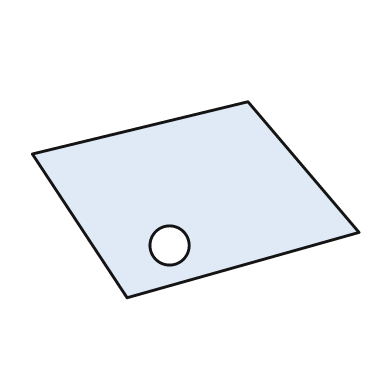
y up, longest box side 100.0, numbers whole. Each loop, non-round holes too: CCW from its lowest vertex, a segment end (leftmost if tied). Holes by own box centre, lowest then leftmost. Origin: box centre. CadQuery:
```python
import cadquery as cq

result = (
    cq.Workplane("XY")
    .moveTo(-21.0, -30.0)
    .lineTo(50.0, -10.0)
    .lineTo(16.0, 30.0)
    .lineTo(-50.0, 14.0)
    .close()
    .moveTo(-8.0, -14.0)
    .circle(6.0)
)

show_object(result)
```